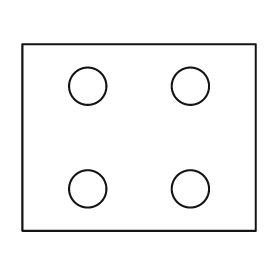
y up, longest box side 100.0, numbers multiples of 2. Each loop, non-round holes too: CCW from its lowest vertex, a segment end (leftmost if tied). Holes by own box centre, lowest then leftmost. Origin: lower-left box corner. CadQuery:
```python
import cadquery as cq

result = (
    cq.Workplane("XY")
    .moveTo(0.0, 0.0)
    .lineTo(100.0, 0.0)
    .lineTo(100.0, 80.0)
    .lineTo(0.0, 80.0)
    .close()
    .moveTo(28.0, 18.0)
    .circle(8.0)
    .moveTo(72.0, 18.0)
    .circle(8.0)
    .moveTo(28.0, 62.0)
    .circle(8.0)
    .moveTo(72.0, 62.0)
    .circle(8.0)
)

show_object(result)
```